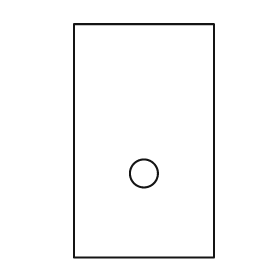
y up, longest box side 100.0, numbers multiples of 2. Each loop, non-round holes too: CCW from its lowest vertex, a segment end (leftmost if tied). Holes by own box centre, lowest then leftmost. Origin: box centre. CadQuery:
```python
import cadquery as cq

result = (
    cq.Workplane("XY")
    .moveTo(-30.0, -50.0)
    .lineTo(30.0, -50.0)
    .lineTo(30.0, 50.0)
    .lineTo(-30.0, 50.0)
    .close()
    .moveTo(0.0, -14.0)
    .circle(6.0)
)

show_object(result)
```